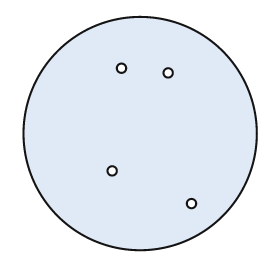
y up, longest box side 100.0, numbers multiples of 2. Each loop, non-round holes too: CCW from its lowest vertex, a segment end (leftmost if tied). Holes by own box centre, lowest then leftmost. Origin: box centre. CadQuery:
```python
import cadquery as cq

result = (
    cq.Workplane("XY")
    .moveTo(0.0, 0.0)
    .circle(50.0)
    .moveTo(22.0, -30.0)
    .circle(2.0)
    .moveTo(-12.0, -16.0)
    .circle(2.0)
    .moveTo(12.0, 26.0)
    .circle(2.0)
    .moveTo(-8.0, 28.0)
    .circle(2.0)
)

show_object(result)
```